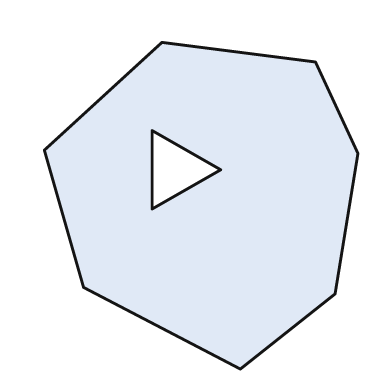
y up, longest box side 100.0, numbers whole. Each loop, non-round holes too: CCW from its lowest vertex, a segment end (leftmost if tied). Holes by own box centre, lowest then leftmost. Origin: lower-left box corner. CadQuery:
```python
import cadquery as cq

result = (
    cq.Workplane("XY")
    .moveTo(60.0, 0.0)
    .lineTo(89.0, 23.0)
    .lineTo(96.0, 66.0)
    .lineTo(83.0, 94.0)
    .lineTo(36.0, 100.0)
    .lineTo(0.0, 67.0)
    .lineTo(12.0, 25.0)
    .close()
    .moveTo(33.0, 49.0)
    .lineTo(54.0, 61.0)
    .lineTo(33.0, 73.0)
    .close()
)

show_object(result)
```